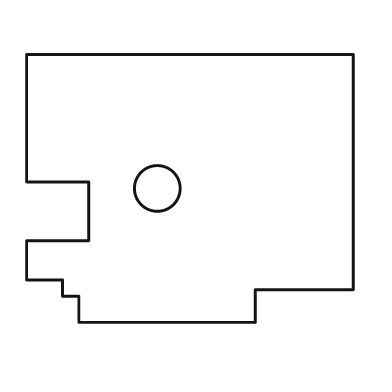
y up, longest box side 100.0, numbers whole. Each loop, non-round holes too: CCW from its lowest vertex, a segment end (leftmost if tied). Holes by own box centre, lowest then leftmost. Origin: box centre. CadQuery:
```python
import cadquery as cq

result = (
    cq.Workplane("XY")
    .moveTo(-34.0, -41.0)
    .lineTo(20.0, -41.0)
    .lineTo(20.0, -31.0)
    .lineTo(50.0, -31.0)
    .lineTo(50.0, 41.0)
    .lineTo(-50.0, 41.0)
    .lineTo(-50.0, 2.0)
    .lineTo(-31.0, 2.0)
    .lineTo(-31.0, -16.0)
    .lineTo(-50.0, -16.0)
    .lineTo(-50.0, -28.0)
    .lineTo(-39.0, -28.0)
    .lineTo(-39.0, -33.0)
    .lineTo(-34.0, -33.0)
    .close()
    .moveTo(-10.0, 0.0)
    .circle(7.0)
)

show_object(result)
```